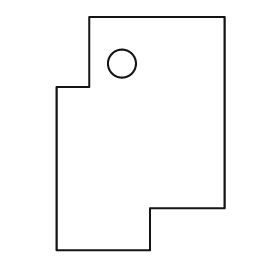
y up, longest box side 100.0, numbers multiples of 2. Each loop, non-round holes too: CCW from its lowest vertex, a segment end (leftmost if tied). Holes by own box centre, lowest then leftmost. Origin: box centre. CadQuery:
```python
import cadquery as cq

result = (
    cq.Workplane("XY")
    .moveTo(-36.0, -50.0)
    .lineTo(4.0, -50.0)
    .lineTo(4.0, -32.0)
    .lineTo(36.0, -32.0)
    .lineTo(36.0, 50.0)
    .lineTo(-22.0, 50.0)
    .lineTo(-22.0, 20.0)
    .lineTo(-36.0, 20.0)
    .close()
    .moveTo(-8.0, 30.0)
    .circle(6.0)
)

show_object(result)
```